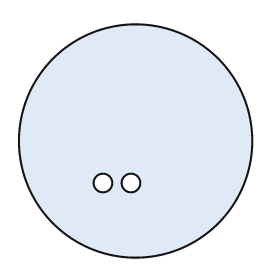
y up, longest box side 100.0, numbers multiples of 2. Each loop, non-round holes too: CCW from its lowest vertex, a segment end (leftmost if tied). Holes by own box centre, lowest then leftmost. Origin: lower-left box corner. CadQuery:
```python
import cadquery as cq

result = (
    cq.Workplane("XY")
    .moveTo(50.0, 50.0)
    .circle(50.0)
    .moveTo(36.0, 32.0)
    .circle(4.0)
    .moveTo(48.0, 32.0)
    .circle(4.0)
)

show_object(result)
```